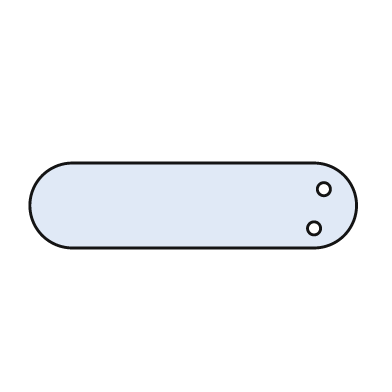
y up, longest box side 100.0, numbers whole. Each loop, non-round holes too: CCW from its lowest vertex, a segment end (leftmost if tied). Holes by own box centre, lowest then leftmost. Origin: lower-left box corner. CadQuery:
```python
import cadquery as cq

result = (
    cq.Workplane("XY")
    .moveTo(13.0, 0.0)
    .lineTo(87.0, 0.0)
    .threePointArc((100.0, 13.0), (87.0, 26.0))
    .lineTo(13.0, 26.0)
    .threePointArc((0.0, 13.0), (13.0, 0.0))
    .close()
    .moveTo(87.0, 6.0)
    .circle(2.0)
    .moveTo(90.0, 18.0)
    .circle(2.0)
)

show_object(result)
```